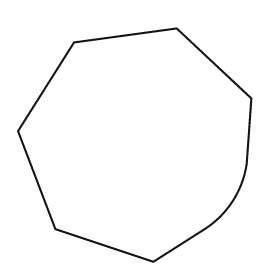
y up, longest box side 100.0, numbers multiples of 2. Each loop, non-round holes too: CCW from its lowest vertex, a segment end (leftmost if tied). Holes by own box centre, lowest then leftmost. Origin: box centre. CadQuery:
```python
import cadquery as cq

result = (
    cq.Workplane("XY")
    .moveTo(8.0, -50.0)
    .lineTo(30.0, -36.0)
    .threePointArc((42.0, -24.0), (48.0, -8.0))
    .lineTo(50.0, 20.0)
    .lineTo(18.0, 50.0)
    .lineTo(-26.0, 44.0)
    .lineTo(-50.0, 6.0)
    .lineTo(-34.0, -36.0)
    .close()
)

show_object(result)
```